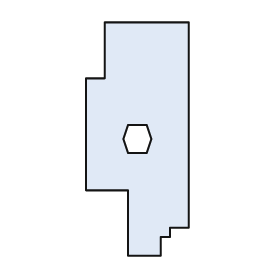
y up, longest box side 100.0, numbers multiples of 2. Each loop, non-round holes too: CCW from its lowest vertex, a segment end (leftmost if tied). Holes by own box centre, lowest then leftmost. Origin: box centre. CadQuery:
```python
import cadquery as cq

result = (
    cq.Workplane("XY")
    .moveTo(-4.0, -50.0)
    .lineTo(10.0, -50.0)
    .lineTo(10.0, -42.0)
    .lineTo(14.0, -42.0)
    .lineTo(14.0, -38.0)
    .lineTo(22.0, -38.0)
    .lineTo(22.0, 50.0)
    .lineTo(-14.0, 50.0)
    .lineTo(-14.0, 26.0)
    .lineTo(-22.0, 26.0)
    .lineTo(-22.0, -22.0)
    .lineTo(-4.0, -22.0)
    .close()
    .moveTo(-4.0, -6.0)
    .lineTo(4.0, -6.0)
    .lineTo(6.0, 0.0)
    .lineTo(4.0, 6.0)
    .lineTo(-4.0, 6.0)
    .lineTo(-6.0, 0.0)
    .close()
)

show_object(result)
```